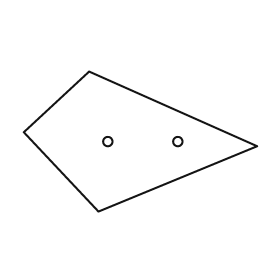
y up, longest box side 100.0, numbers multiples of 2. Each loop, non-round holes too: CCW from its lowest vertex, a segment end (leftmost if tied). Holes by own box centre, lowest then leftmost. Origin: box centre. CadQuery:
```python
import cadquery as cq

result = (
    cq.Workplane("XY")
    .moveTo(-18.0, -30.0)
    .lineTo(50.0, -2.0)
    .lineTo(-22.0, 30.0)
    .lineTo(-50.0, 4.0)
    .close()
    .moveTo(-14.0, 0.0)
    .circle(2.0)
    .moveTo(16.0, 0.0)
    .circle(2.0)
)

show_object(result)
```